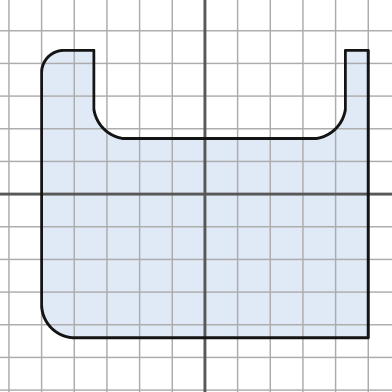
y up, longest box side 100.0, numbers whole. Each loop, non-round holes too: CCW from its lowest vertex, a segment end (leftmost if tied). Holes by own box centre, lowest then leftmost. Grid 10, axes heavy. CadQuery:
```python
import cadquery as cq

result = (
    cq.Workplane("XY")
    .moveTo(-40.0, -44.0)
    .lineTo(50.0, -44.0)
    .lineTo(50.0, 44.0)
    .lineTo(43.0, 44.0)
    .lineTo(43.0, 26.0)
    .threePointArc((40.0, 20.0), (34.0, 17.0))
    .lineTo(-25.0, 17.0)
    .threePointArc((-31.0, 20.0), (-34.0, 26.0))
    .lineTo(-34.0, 44.0)
    .lineTo(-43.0, 44.0)
    .threePointArc((-48.0, 42.0), (-50.0, 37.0))
    .lineTo(-50.0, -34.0)
    .threePointArc((-47.0, -41.0), (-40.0, -44.0))
    .close()
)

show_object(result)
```